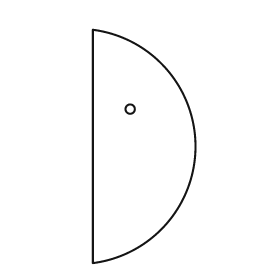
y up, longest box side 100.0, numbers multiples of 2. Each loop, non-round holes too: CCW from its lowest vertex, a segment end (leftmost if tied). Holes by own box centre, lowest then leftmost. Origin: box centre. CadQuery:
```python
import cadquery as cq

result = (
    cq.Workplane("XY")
    .moveTo(-22.0, -50.0)
    .threePointArc((22.0, 0.0), (-22.0, 50.0))
    .close()
    .moveTo(-6.0, 16.0)
    .circle(2.0)
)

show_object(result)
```